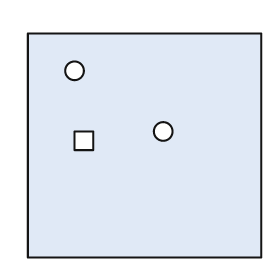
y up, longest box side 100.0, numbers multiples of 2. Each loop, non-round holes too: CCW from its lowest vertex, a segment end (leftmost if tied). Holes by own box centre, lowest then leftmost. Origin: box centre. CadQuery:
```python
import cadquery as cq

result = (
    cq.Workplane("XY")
    .moveTo(-50.0, -48.0)
    .lineTo(50.0, -48.0)
    .lineTo(50.0, 48.0)
    .lineTo(-50.0, 48.0)
    .close()
    .moveTo(-30.0, -2.0)
    .lineTo(-22.0, -2.0)
    .lineTo(-22.0, 6.0)
    .lineTo(-30.0, 6.0)
    .close()
    .moveTo(8.0, 6.0)
    .circle(4.0)
    .moveTo(-30.0, 32.0)
    .circle(4.0)
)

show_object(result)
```